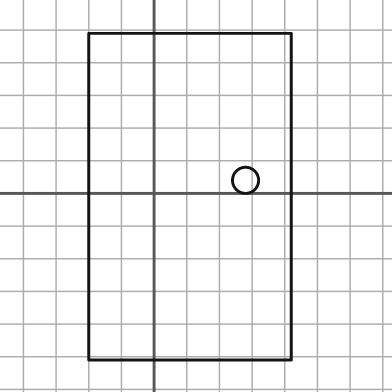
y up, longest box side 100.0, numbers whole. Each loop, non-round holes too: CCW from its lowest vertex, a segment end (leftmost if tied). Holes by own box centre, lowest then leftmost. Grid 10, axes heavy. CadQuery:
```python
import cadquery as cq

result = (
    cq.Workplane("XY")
    .moveTo(-20.0, -51.0)
    .lineTo(42.0, -51.0)
    .lineTo(42.0, 49.0)
    .lineTo(-20.0, 49.0)
    .close()
    .moveTo(28.0, 4.0)
    .circle(4.0)
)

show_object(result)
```